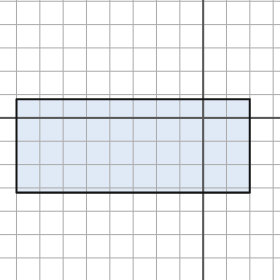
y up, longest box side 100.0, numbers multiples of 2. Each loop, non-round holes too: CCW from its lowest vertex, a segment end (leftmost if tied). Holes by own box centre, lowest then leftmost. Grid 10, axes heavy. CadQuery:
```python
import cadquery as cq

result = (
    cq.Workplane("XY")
    .moveTo(-80.0, -32.0)
    .lineTo(20.0, -32.0)
    .lineTo(20.0, 8.0)
    .lineTo(-80.0, 8.0)
    .close()
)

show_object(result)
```